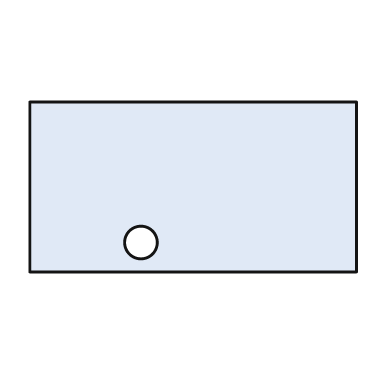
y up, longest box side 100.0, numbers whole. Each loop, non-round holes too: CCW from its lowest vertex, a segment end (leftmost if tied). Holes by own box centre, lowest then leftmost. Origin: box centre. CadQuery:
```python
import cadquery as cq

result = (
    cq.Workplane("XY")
    .moveTo(-50.0, -26.0)
    .lineTo(50.0, -26.0)
    .lineTo(50.0, 26.0)
    .lineTo(-50.0, 26.0)
    .close()
    .moveTo(-16.0, -17.0)
    .circle(5.0)
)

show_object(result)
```